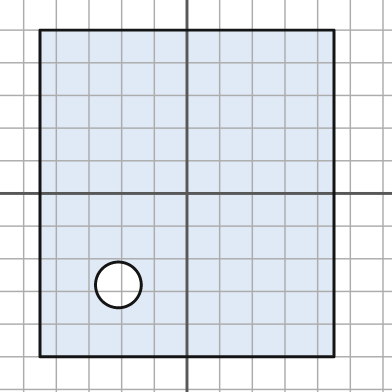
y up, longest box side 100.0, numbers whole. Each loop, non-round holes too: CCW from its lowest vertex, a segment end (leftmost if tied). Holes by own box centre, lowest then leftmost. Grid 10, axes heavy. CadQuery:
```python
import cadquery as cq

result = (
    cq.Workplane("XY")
    .moveTo(-45.0, -50.0)
    .lineTo(45.0, -50.0)
    .lineTo(45.0, 50.0)
    .lineTo(-45.0, 50.0)
    .close()
    .moveTo(-21.0, -28.0)
    .circle(7.0)
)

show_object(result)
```